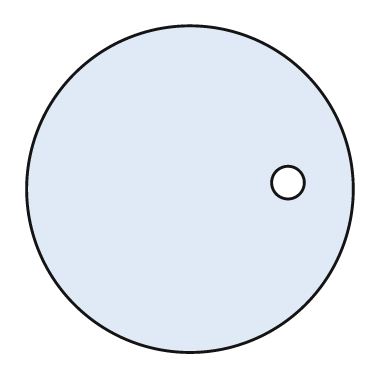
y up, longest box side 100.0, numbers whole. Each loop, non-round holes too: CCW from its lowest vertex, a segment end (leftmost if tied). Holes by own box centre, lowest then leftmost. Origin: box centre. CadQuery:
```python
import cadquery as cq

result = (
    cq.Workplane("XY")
    .moveTo(0.0, 0.0)
    .circle(50.0)
    .moveTo(30.0, 2.0)
    .circle(5.0)
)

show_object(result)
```